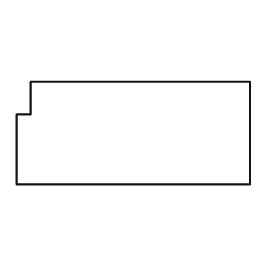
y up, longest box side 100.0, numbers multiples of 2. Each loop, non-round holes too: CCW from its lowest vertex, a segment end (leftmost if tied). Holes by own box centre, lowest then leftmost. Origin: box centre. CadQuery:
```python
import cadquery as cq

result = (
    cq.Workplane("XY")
    .moveTo(-50.0, -22.0)
    .lineTo(50.0, -22.0)
    .lineTo(50.0, 22.0)
    .lineTo(-44.0, 22.0)
    .lineTo(-44.0, 8.0)
    .lineTo(-50.0, 8.0)
    .close()
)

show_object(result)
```